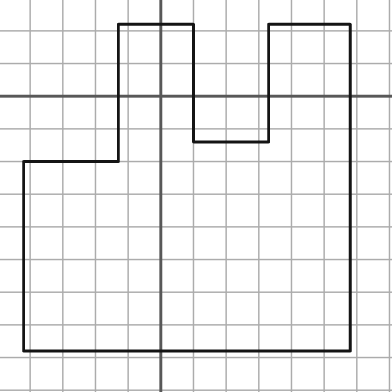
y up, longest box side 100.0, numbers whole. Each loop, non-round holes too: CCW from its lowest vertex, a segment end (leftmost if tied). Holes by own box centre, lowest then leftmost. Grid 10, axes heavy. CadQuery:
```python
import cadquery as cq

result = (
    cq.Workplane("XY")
    .moveTo(-42.0, -78.0)
    .lineTo(58.0, -78.0)
    .lineTo(58.0, 22.0)
    .lineTo(33.0, 22.0)
    .lineTo(33.0, -14.0)
    .lineTo(10.0, -14.0)
    .lineTo(10.0, 22.0)
    .lineTo(-13.0, 22.0)
    .lineTo(-13.0, -20.0)
    .lineTo(-42.0, -20.0)
    .close()
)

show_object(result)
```